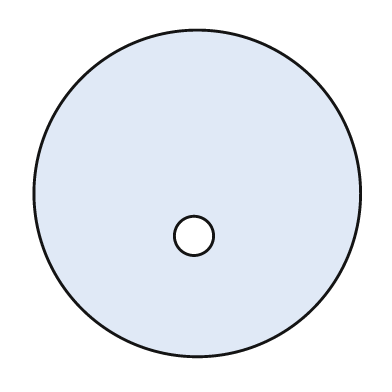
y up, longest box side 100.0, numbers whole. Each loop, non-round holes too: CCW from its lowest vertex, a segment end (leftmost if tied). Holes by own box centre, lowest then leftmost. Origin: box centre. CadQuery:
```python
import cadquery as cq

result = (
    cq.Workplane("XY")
    .moveTo(0.0, 0.0)
    .circle(50.0)
    .moveTo(-1.0, -13.0)
    .circle(6.0)
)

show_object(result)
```